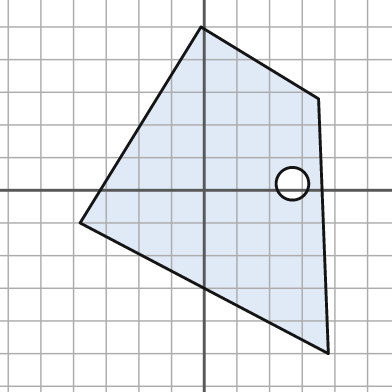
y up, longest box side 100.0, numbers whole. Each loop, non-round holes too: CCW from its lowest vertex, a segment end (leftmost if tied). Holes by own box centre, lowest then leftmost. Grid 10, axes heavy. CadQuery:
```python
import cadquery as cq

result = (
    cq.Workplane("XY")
    .moveTo(38.0, -50.0)
    .lineTo(35.0, 28.0)
    .lineTo(-1.0, 50.0)
    .lineTo(-38.0, -10.0)
    .close()
    .moveTo(27.0, 2.0)
    .circle(5.0)
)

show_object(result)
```